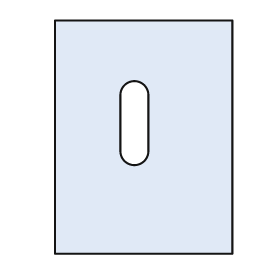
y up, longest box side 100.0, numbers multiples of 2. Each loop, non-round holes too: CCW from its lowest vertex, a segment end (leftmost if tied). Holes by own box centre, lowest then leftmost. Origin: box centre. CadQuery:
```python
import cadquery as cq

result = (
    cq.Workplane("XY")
    .moveTo(-38.0, -50.0)
    .lineTo(38.0, -50.0)
    .lineTo(38.0, 50.0)
    .lineTo(-38.0, 50.0)
    .close()
    .moveTo(-10.0, -6.0)
    .threePointArc((-4.0, -12.0), (2.0, -6.0))
    .lineTo(2.0, 18.0)
    .threePointArc((-4.0, 24.0), (-10.0, 18.0))
    .close()
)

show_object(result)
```